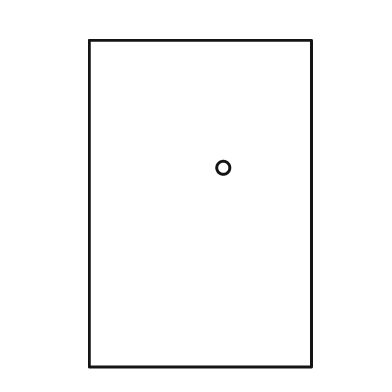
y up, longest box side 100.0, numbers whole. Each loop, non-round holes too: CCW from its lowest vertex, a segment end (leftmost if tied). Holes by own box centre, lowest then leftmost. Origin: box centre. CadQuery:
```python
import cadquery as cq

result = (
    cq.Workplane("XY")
    .moveTo(-34.0, -50.0)
    .lineTo(34.0, -50.0)
    .lineTo(34.0, 50.0)
    .lineTo(-34.0, 50.0)
    .close()
    .moveTo(7.0, 11.0)
    .circle(2.0)
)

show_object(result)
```